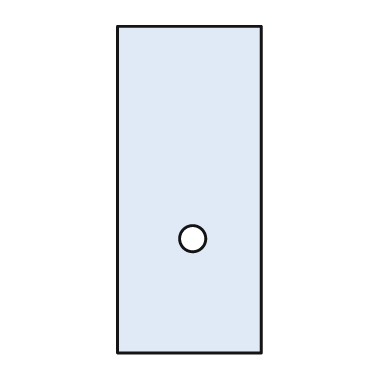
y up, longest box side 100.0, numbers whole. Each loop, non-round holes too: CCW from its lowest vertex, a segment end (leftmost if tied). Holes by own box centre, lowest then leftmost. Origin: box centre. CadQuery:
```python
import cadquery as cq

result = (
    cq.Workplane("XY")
    .moveTo(-22.0, -50.0)
    .lineTo(22.0, -50.0)
    .lineTo(22.0, 50.0)
    .lineTo(-22.0, 50.0)
    .close()
    .moveTo(1.0, -15.0)
    .circle(4.0)
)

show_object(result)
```